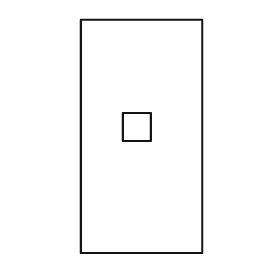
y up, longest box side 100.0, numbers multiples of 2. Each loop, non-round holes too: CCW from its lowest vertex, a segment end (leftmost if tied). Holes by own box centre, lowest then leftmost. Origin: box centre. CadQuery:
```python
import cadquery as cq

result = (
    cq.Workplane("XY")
    .moveTo(-26.0, -50.0)
    .lineTo(26.0, -50.0)
    .lineTo(26.0, 50.0)
    .lineTo(-26.0, 50.0)
    .close()
    .moveTo(-8.0, -2.0)
    .lineTo(4.0, -2.0)
    .lineTo(4.0, 10.0)
    .lineTo(-8.0, 10.0)
    .close()
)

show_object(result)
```